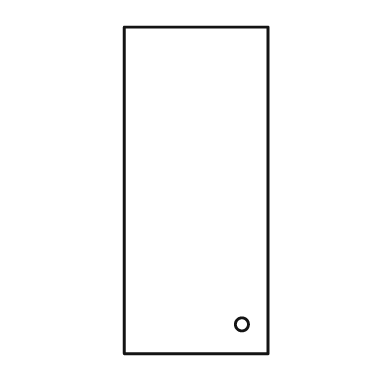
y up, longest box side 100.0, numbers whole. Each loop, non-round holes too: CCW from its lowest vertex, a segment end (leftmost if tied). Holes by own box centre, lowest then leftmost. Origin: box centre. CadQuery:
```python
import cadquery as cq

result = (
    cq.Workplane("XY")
    .moveTo(-22.0, -50.0)
    .lineTo(22.0, -50.0)
    .lineTo(22.0, 50.0)
    .lineTo(-22.0, 50.0)
    .close()
    .moveTo(14.0, -41.0)
    .circle(2.0)
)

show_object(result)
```